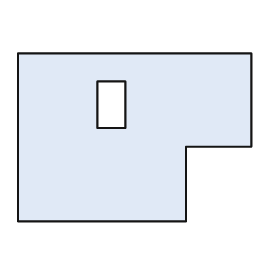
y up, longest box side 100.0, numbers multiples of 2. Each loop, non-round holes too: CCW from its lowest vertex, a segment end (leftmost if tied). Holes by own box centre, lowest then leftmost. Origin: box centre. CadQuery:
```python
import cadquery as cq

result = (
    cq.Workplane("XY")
    .moveTo(-50.0, -36.0)
    .lineTo(22.0, -36.0)
    .lineTo(22.0, -4.0)
    .lineTo(50.0, -4.0)
    .lineTo(50.0, 36.0)
    .lineTo(-50.0, 36.0)
    .close()
    .moveTo(-16.0, 4.0)
    .lineTo(-4.0, 4.0)
    .lineTo(-4.0, 24.0)
    .lineTo(-16.0, 24.0)
    .close()
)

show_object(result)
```